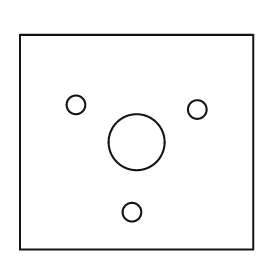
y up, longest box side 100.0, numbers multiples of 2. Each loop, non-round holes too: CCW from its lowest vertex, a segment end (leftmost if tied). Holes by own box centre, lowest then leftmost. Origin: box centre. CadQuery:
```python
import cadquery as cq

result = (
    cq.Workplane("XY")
    .moveTo(-50.0, -46.0)
    .lineTo(50.0, -46.0)
    .lineTo(50.0, 46.0)
    .lineTo(-50.0, 46.0)
    .close()
    .moveTo(-2.0, -30.0)
    .circle(4.0)
    .moveTo(0.0, 0.0)
    .circle(12.0)
    .moveTo(26.0, 14.0)
    .circle(4.0)
    .moveTo(-26.0, 16.0)
    .circle(4.0)
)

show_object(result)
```